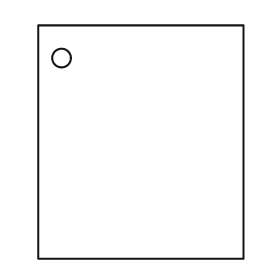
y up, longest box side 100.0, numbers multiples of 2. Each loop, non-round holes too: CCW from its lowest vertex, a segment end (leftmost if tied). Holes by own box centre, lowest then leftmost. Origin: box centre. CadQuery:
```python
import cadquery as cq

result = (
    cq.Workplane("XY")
    .moveTo(-44.0, -50.0)
    .lineTo(44.0, -50.0)
    .lineTo(44.0, 50.0)
    .lineTo(-44.0, 50.0)
    .close()
    .moveTo(-34.0, 36.0)
    .circle(4.0)
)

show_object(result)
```